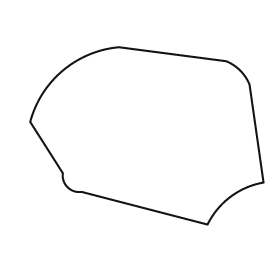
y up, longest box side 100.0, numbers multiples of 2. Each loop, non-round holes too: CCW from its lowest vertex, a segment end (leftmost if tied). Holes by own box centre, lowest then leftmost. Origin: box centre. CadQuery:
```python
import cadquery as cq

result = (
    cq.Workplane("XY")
    .moveTo(26.0, -38.0)
    .threePointArc((36.0, -26.0), (50.0, -20.0))
    .lineTo(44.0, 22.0)
    .threePointArc((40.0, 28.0), (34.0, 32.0))
    .lineTo(-12.0, 38.0)
    .threePointArc((-36.0, 28.0), (-50.0, 6.0))
    .lineTo(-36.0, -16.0)
    .threePointArc((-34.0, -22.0), (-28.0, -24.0))
    .close()
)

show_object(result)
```